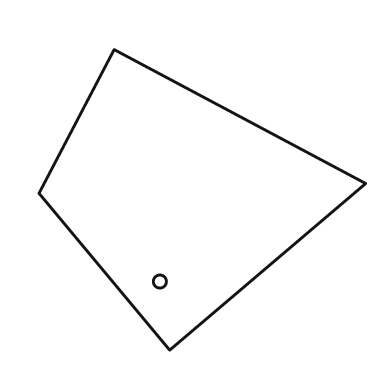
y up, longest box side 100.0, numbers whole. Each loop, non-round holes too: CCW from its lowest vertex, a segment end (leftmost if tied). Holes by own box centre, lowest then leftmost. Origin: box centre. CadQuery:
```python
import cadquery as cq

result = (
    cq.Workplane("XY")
    .moveTo(-10.0, -46.0)
    .lineTo(50.0, 5.0)
    .lineTo(-27.0, 46.0)
    .lineTo(-50.0, 2.0)
    .close()
    .moveTo(-13.0, -25.0)
    .circle(2.0)
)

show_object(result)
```